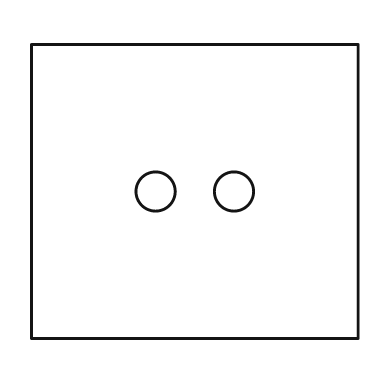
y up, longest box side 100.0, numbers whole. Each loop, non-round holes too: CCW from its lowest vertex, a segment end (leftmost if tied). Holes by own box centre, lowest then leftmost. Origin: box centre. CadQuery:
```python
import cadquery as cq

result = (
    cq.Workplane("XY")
    .moveTo(-50.0, -45.0)
    .lineTo(50.0, -45.0)
    .lineTo(50.0, 45.0)
    .lineTo(-50.0, 45.0)
    .close()
    .moveTo(-12.0, 0.0)
    .circle(6.0)
    .moveTo(12.0, 0.0)
    .circle(6.0)
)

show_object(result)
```